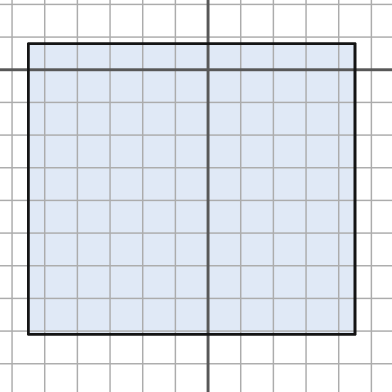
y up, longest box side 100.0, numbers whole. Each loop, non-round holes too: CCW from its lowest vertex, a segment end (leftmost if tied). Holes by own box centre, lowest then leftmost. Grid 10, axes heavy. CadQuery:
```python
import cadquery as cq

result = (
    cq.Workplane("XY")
    .moveTo(-55.0, -81.0)
    .lineTo(45.0, -81.0)
    .lineTo(45.0, 8.0)
    .lineTo(-55.0, 8.0)
    .close()
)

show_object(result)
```